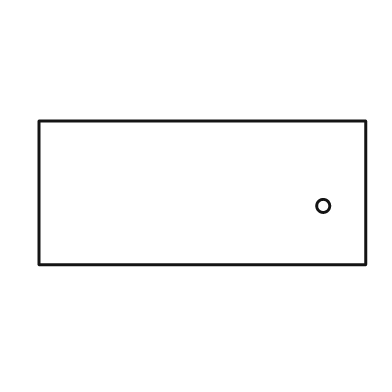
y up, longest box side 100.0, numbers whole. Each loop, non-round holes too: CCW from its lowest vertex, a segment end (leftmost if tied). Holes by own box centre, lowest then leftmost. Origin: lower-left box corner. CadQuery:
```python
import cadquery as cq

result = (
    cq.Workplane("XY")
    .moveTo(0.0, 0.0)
    .lineTo(100.0, 0.0)
    .lineTo(100.0, 44.0)
    .lineTo(0.0, 44.0)
    .close()
    .moveTo(87.0, 18.0)
    .circle(2.0)
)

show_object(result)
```